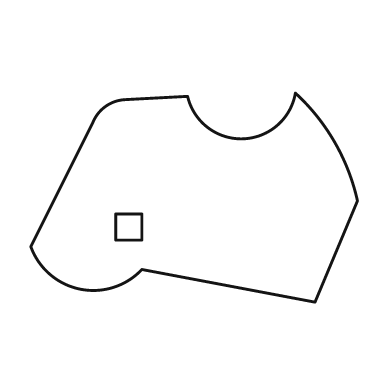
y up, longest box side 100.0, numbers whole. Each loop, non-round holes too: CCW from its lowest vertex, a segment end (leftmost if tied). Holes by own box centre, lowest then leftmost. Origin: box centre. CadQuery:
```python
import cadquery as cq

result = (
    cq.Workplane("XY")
    .moveTo(37.0, -32.0)
    .lineTo(50.0, -1.0)
    .threePointArc((43.0, 17.0), (31.0, 32.0))
    .threePointArc((15.0, 18.0), (-2.0, 31.0))
    .lineTo(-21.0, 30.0)
    .threePointArc((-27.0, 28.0), (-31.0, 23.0))
    .lineTo(-50.0, -15.0)
    .threePointArc((-35.0, -28.0), (-16.0, -22.0))
    .close()
    .moveTo(-24.0, -13.0)
    .lineTo(-16.0, -13.0)
    .lineTo(-16.0, -5.0)
    .lineTo(-24.0, -5.0)
    .close()
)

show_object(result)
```